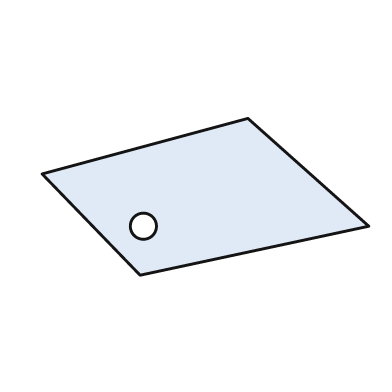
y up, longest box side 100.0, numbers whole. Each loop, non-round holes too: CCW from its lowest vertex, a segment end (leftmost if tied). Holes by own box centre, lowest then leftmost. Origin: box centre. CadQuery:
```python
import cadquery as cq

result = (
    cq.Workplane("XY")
    .moveTo(-20.0, -24.0)
    .lineTo(50.0, -9.0)
    .lineTo(13.0, 24.0)
    .lineTo(-50.0, 7.0)
    .close()
    .moveTo(-19.0, -9.0)
    .circle(4.0)
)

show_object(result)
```